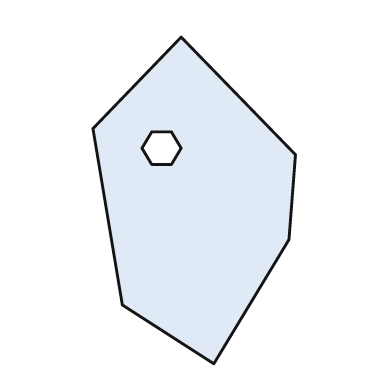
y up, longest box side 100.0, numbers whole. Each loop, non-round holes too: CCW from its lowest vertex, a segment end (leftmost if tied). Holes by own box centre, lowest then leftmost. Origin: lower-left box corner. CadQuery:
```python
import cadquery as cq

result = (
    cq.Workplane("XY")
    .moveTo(37.0, 0.0)
    .lineTo(60.0, 38.0)
    .lineTo(62.0, 64.0)
    .lineTo(27.0, 100.0)
    .lineTo(0.0, 72.0)
    .lineTo(9.0, 18.0)
    .close()
    .moveTo(18.0, 61.0)
    .lineTo(24.0, 61.0)
    .lineTo(27.0, 66.0)
    .lineTo(24.0, 71.0)
    .lineTo(18.0, 71.0)
    .lineTo(15.0, 66.0)
    .close()
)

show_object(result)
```